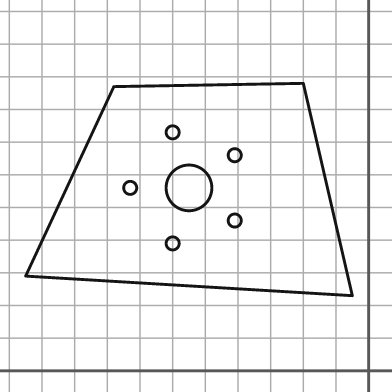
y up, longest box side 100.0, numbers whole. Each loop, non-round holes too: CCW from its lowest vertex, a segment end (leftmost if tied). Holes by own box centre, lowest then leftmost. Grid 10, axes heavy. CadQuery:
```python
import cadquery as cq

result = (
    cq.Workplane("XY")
    .moveTo(-5.0, 23.0)
    .lineTo(-20.0, 88.0)
    .lineTo(-78.0, 87.0)
    .lineTo(-105.0, 29.0)
    .close()
    .moveTo(-60.0, 39.0)
    .circle(2.0)
    .moveTo(-41.0, 46.0)
    .circle(2.0)
    .moveTo(-73.0, 56.0)
    .circle(2.0)
    .moveTo(-55.0, 56.0)
    .circle(7.0)
    .moveTo(-41.0, 66.0)
    .circle(2.0)
    .moveTo(-60.0, 73.0)
    .circle(2.0)
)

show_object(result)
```